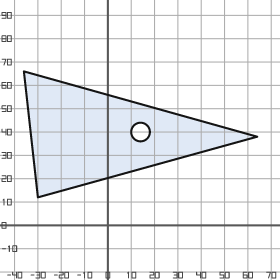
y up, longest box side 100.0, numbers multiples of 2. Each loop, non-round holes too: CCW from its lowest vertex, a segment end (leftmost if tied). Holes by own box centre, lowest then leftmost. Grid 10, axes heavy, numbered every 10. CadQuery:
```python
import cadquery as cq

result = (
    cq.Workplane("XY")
    .moveTo(-30.0, 12.0)
    .lineTo(64.0, 38.0)
    .lineTo(-36.0, 66.0)
    .close()
    .moveTo(14.0, 40.0)
    .circle(4.0)
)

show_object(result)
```